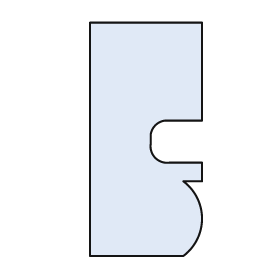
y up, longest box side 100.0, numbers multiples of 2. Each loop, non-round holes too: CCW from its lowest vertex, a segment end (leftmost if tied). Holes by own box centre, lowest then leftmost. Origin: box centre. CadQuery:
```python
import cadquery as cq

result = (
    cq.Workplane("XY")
    .moveTo(-24.0, -50.0)
    .lineTo(16.0, -50.0)
    .threePointArc((24.0, -34.0), (16.0, -18.0))
    .lineTo(24.0, -18.0)
    .lineTo(24.0, -10.0)
    .lineTo(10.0, -10.0)
    .threePointArc((4.0, -8.0), (2.0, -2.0))
    .lineTo(2.0, 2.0)
    .threePointArc((4.0, 6.0), (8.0, 8.0))
    .lineTo(24.0, 8.0)
    .lineTo(24.0, 50.0)
    .lineTo(-24.0, 50.0)
    .close()
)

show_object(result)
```